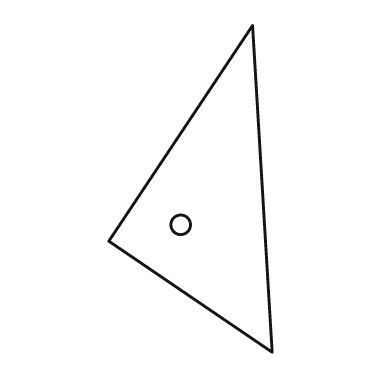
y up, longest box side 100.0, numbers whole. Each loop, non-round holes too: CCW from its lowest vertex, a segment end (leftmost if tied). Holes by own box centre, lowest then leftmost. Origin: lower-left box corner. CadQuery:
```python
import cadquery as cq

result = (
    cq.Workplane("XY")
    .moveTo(50.0, 0.0)
    .lineTo(44.0, 100.0)
    .lineTo(0.0, 34.0)
    .close()
    .moveTo(22.0, 39.0)
    .circle(3.0)
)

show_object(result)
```